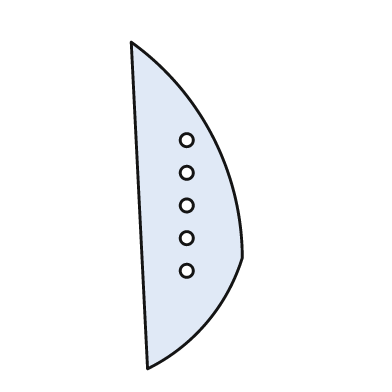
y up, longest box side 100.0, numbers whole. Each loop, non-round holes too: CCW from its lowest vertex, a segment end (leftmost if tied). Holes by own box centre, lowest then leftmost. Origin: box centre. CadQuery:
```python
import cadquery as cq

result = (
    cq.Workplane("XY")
    .moveTo(-12.0, -50.0)
    .threePointArc((6.0, -36.0), (17.0, -16.0))
    .threePointArc((8.0, 21.0), (-17.0, 50.0))
    .close()
    .moveTo(0.0, -20.0)
    .circle(2.0)
    .moveTo(0.0, -10.0)
    .circle(2.0)
    .moveTo(0.0, 0.0)
    .circle(2.0)
    .moveTo(0.0, 10.0)
    .circle(2.0)
    .moveTo(0.0, 20.0)
    .circle(2.0)
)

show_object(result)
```